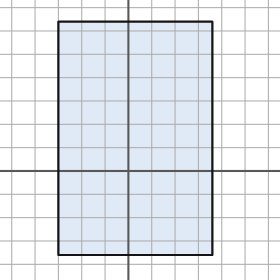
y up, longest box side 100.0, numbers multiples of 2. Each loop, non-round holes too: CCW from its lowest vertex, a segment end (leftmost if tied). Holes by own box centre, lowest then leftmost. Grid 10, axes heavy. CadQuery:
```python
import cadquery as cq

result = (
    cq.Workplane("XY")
    .moveTo(-30.0, -36.0)
    .lineTo(36.0, -36.0)
    .lineTo(36.0, 64.0)
    .lineTo(-30.0, 64.0)
    .close()
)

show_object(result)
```